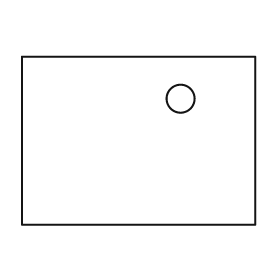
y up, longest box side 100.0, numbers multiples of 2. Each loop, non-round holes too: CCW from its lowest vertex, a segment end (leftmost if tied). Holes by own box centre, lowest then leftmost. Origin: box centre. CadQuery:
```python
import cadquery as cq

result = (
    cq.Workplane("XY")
    .moveTo(-50.0, -36.0)
    .lineTo(50.0, -36.0)
    .lineTo(50.0, 36.0)
    .lineTo(-50.0, 36.0)
    .close()
    .moveTo(18.0, 18.0)
    .circle(6.0)
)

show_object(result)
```